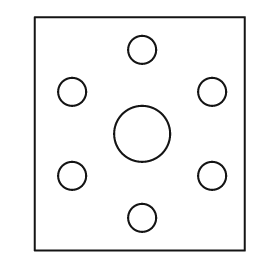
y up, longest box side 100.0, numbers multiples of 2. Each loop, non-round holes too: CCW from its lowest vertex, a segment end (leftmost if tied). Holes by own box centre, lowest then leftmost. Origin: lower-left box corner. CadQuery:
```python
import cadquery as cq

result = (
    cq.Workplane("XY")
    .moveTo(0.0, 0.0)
    .lineTo(90.0, 0.0)
    .lineTo(90.0, 100.0)
    .lineTo(0.0, 100.0)
    .close()
    .moveTo(46.0, 14.0)
    .circle(6.0)
    .moveTo(16.0, 32.0)
    .circle(6.0)
    .moveTo(76.0, 32.0)
    .circle(6.0)
    .moveTo(46.0, 50.0)
    .circle(12.0)
    .moveTo(16.0, 68.0)
    .circle(6.0)
    .moveTo(76.0, 68.0)
    .circle(6.0)
    .moveTo(46.0, 86.0)
    .circle(6.0)
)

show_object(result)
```